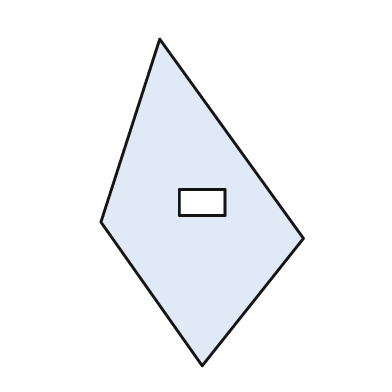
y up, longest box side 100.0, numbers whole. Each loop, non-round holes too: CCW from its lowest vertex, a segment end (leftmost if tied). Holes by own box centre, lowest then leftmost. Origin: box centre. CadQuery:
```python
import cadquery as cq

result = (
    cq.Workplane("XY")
    .moveTo(0.0, -50.0)
    .lineTo(31.0, -11.0)
    .lineTo(-13.0, 50.0)
    .lineTo(-31.0, -6.0)
    .close()
    .moveTo(-7.0, -4.0)
    .lineTo(7.0, -4.0)
    .lineTo(7.0, 4.0)
    .lineTo(-7.0, 4.0)
    .close()
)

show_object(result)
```